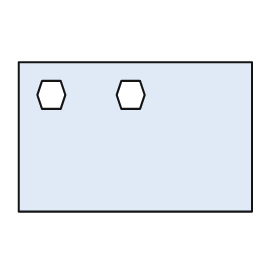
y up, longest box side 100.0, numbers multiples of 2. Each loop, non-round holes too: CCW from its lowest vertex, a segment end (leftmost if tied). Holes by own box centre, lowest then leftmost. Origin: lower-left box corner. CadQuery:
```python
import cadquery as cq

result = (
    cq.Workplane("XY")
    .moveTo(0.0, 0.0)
    .lineTo(100.0, 0.0)
    .lineTo(100.0, 64.0)
    .lineTo(0.0, 64.0)
    .close()
    .moveTo(10.0, 44.0)
    .lineTo(18.0, 44.0)
    .lineTo(20.0, 50.0)
    .lineTo(18.0, 56.0)
    .lineTo(10.0, 56.0)
    .lineTo(8.0, 50.0)
    .close()
    .moveTo(44.0, 44.0)
    .lineTo(52.0, 44.0)
    .lineTo(54.0, 50.0)
    .lineTo(52.0, 56.0)
    .lineTo(44.0, 56.0)
    .lineTo(42.0, 50.0)
    .close()
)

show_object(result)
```